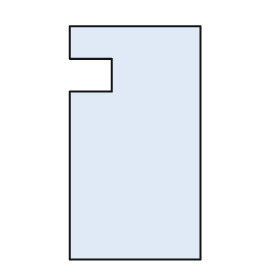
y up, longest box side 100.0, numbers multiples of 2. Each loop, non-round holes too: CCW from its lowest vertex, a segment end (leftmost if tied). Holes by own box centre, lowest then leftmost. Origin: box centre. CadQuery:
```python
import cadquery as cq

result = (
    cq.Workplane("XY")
    .moveTo(-28.0, -50.0)
    .lineTo(28.0, -50.0)
    .lineTo(28.0, 50.0)
    .lineTo(-28.0, 50.0)
    .lineTo(-28.0, 36.0)
    .lineTo(-10.0, 36.0)
    .lineTo(-10.0, 22.0)
    .lineTo(-28.0, 22.0)
    .close()
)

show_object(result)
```